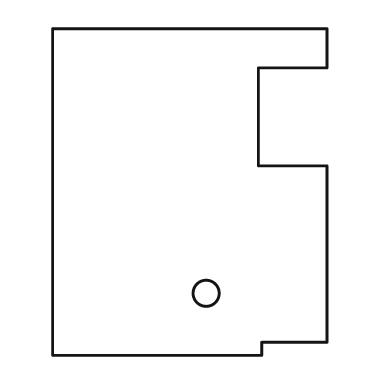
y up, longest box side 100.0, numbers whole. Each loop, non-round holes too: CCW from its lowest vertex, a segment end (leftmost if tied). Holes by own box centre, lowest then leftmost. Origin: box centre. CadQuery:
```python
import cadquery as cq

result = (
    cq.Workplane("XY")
    .moveTo(-42.0, -50.0)
    .lineTo(22.0, -50.0)
    .lineTo(22.0, -46.0)
    .lineTo(42.0, -46.0)
    .lineTo(42.0, 8.0)
    .lineTo(21.0, 8.0)
    .lineTo(21.0, 38.0)
    .lineTo(42.0, 38.0)
    .lineTo(42.0, 50.0)
    .lineTo(-42.0, 50.0)
    .close()
    .moveTo(5.0, -31.0)
    .circle(4.0)
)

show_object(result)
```